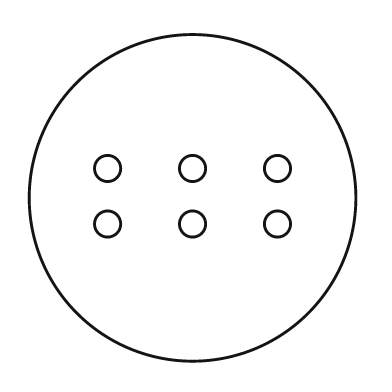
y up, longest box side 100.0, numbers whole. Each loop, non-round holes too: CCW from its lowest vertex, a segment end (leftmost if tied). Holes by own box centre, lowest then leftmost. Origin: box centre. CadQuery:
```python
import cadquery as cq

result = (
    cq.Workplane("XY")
    .moveTo(0.0, 0.0)
    .circle(50.0)
    .moveTo(-26.0, -8.0)
    .circle(4.0)
    .moveTo(0.0, -8.0)
    .circle(4.0)
    .moveTo(26.0, -8.0)
    .circle(4.0)
    .moveTo(-26.0, 9.0)
    .circle(4.0)
    .moveTo(0.0, 9.0)
    .circle(4.0)
    .moveTo(26.0, 9.0)
    .circle(4.0)
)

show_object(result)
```